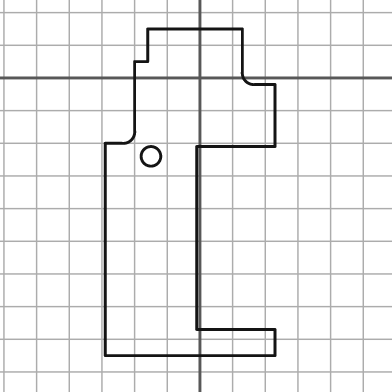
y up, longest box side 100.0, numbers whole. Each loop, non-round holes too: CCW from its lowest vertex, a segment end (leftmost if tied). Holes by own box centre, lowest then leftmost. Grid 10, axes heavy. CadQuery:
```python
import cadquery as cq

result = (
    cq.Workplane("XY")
    .moveTo(-29.0, -85.0)
    .lineTo(23.0, -85.0)
    .lineTo(23.0, -77.0)
    .lineTo(-1.0, -77.0)
    .lineTo(-1.0, -21.0)
    .lineTo(23.0, -21.0)
    .lineTo(23.0, -2.0)
    .lineTo(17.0, -2.0)
    .threePointArc((14.0, -1.0), (13.0, 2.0))
    .lineTo(13.0, 15.0)
    .lineTo(-16.0, 15.0)
    .lineTo(-16.0, 5.0)
    .lineTo(-20.0, 5.0)
    .lineTo(-20.0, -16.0)
    .threePointArc((-21.0, -19.0), (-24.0, -20.0))
    .lineTo(-29.0, -20.0)
    .close()
    .moveTo(-15.0, -24.0)
    .circle(3.0)
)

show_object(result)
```